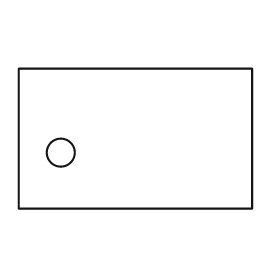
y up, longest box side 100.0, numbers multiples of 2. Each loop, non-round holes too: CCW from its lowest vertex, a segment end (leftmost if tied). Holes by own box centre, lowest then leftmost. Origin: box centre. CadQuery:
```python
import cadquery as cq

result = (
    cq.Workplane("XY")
    .moveTo(-50.0, -30.0)
    .lineTo(50.0, -30.0)
    .lineTo(50.0, 30.0)
    .lineTo(-50.0, 30.0)
    .close()
    .moveTo(-32.0, -6.0)
    .circle(6.0)
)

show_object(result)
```